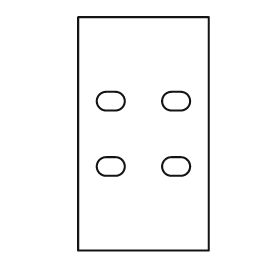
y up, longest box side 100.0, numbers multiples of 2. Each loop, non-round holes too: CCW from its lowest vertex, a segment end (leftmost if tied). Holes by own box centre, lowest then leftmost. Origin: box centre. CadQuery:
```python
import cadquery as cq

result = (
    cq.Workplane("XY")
    .moveTo(-28.0, -50.0)
    .lineTo(28.0, -50.0)
    .lineTo(28.0, 50.0)
    .lineTo(-28.0, 50.0)
    .close()
    .moveTo(-16.0, -18.0)
    .lineTo(-12.0, -18.0)
    .threePointArc((-8.0, -14.0), (-12.0, -10.0))
    .lineTo(-16.0, -10.0)
    .threePointArc((-20.0, -14.0), (-16.0, -18.0))
    .close()
    .moveTo(12.0, -18.0)
    .lineTo(16.0, -18.0)
    .threePointArc((20.0, -14.0), (16.0, -10.0))
    .lineTo(12.0, -10.0)
    .threePointArc((8.0, -14.0), (12.0, -18.0))
    .close()
    .moveTo(-16.0, 10.0)
    .lineTo(-12.0, 10.0)
    .threePointArc((-8.0, 14.0), (-12.0, 18.0))
    .lineTo(-16.0, 18.0)
    .threePointArc((-20.0, 14.0), (-16.0, 10.0))
    .close()
    .moveTo(12.0, 10.0)
    .lineTo(16.0, 10.0)
    .threePointArc((20.0, 14.0), (16.0, 18.0))
    .lineTo(12.0, 18.0)
    .threePointArc((8.0, 14.0), (12.0, 10.0))
    .close()
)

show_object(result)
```